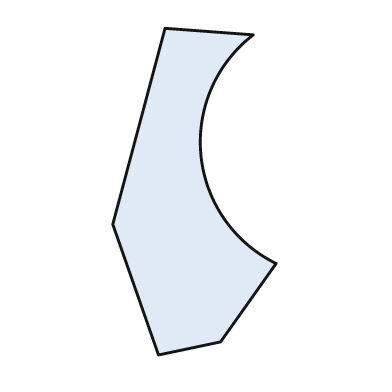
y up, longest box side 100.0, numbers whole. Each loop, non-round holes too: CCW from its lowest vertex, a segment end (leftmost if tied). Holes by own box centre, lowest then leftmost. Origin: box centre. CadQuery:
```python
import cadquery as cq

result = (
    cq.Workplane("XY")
    .moveTo(-11.0, -50.0)
    .lineTo(8.0, -46.0)
    .lineTo(25.0, -22.0)
    .threePointArc((2.0, 11.0), (18.0, 48.0))
    .lineTo(-9.0, 50.0)
    .lineTo(-25.0, -10.0)
    .close()
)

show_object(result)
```